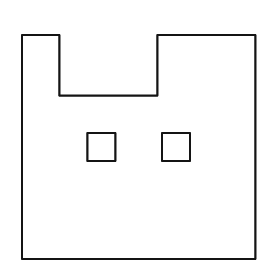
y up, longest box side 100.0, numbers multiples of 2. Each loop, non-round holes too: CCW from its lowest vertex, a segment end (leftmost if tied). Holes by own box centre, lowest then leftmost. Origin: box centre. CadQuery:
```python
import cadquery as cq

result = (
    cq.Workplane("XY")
    .moveTo(-50.0, -48.0)
    .lineTo(50.0, -48.0)
    .lineTo(50.0, 48.0)
    .lineTo(8.0, 48.0)
    .lineTo(8.0, 22.0)
    .lineTo(-34.0, 22.0)
    .lineTo(-34.0, 48.0)
    .lineTo(-50.0, 48.0)
    .close()
    .moveTo(-22.0, -6.0)
    .lineTo(-10.0, -6.0)
    .lineTo(-10.0, 6.0)
    .lineTo(-22.0, 6.0)
    .close()
    .moveTo(10.0, -6.0)
    .lineTo(22.0, -6.0)
    .lineTo(22.0, 6.0)
    .lineTo(10.0, 6.0)
    .close()
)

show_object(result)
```